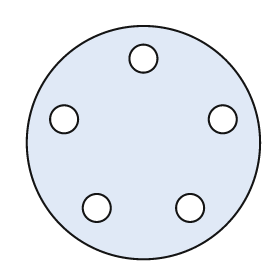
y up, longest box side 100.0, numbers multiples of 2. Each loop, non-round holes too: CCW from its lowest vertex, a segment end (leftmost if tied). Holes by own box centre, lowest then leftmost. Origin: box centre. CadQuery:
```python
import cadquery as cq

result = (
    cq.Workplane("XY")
    .moveTo(0.0, 0.0)
    .circle(50.0)
    .moveTo(-20.0, -28.0)
    .circle(6.0)
    .moveTo(20.0, -28.0)
    .circle(6.0)
    .moveTo(-34.0, 10.0)
    .circle(6.0)
    .moveTo(34.0, 10.0)
    .circle(6.0)
    .moveTo(0.0, 36.0)
    .circle(6.0)
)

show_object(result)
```